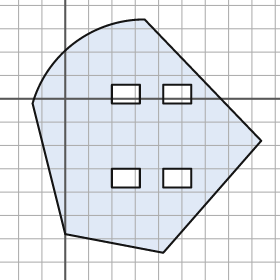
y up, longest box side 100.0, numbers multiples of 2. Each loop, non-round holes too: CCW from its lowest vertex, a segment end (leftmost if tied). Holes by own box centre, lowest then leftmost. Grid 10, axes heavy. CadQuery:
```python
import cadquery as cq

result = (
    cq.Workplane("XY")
    .moveTo(42.0, -66.0)
    .lineTo(84.0, -18.0)
    .lineTo(34.0, 34.0)
    .threePointArc((4.0, 24.0), (-14.0, -2.0))
    .lineTo(0.0, -58.0)
    .close()
    .moveTo(20.0, -38.0)
    .lineTo(32.0, -38.0)
    .lineTo(32.0, -30.0)
    .lineTo(20.0, -30.0)
    .close()
    .moveTo(42.0, -38.0)
    .lineTo(54.0, -38.0)
    .lineTo(54.0, -30.0)
    .lineTo(42.0, -30.0)
    .close()
    .moveTo(20.0, -2.0)
    .lineTo(32.0, -2.0)
    .lineTo(32.0, 6.0)
    .lineTo(20.0, 6.0)
    .close()
    .moveTo(42.0, -2.0)
    .lineTo(54.0, -2.0)
    .lineTo(54.0, 6.0)
    .lineTo(42.0, 6.0)
    .close()
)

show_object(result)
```